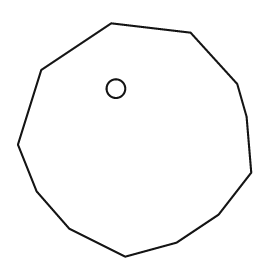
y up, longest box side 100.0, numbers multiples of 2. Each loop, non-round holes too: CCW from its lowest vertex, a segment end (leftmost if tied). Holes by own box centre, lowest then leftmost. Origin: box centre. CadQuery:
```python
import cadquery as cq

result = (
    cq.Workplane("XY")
    .moveTo(-4.0, -50.0)
    .lineTo(18.0, -44.0)
    .lineTo(36.0, -32.0)
    .lineTo(50.0, -14.0)
    .lineTo(48.0, 10.0)
    .lineTo(44.0, 24.0)
    .lineTo(24.0, 46.0)
    .lineTo(-10.0, 50.0)
    .lineTo(-40.0, 30.0)
    .lineTo(-50.0, -2.0)
    .lineTo(-42.0, -22.0)
    .lineTo(-28.0, -38.0)
    .close()
    .moveTo(-8.0, 22.0)
    .circle(4.0)
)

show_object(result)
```